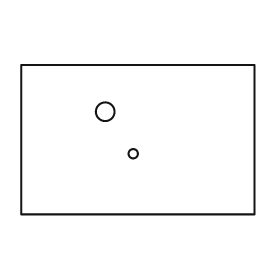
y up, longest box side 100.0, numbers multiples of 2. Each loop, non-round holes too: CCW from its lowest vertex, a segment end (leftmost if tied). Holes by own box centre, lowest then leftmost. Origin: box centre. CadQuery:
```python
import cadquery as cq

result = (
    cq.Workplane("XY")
    .moveTo(-50.0, -32.0)
    .lineTo(50.0, -32.0)
    .lineTo(50.0, 32.0)
    .lineTo(-50.0, 32.0)
    .close()
    .moveTo(-2.0, -6.0)
    .circle(2.0)
    .moveTo(-14.0, 12.0)
    .circle(4.0)
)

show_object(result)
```